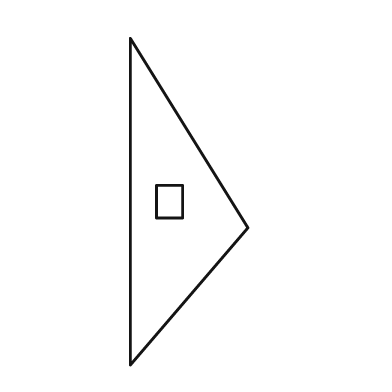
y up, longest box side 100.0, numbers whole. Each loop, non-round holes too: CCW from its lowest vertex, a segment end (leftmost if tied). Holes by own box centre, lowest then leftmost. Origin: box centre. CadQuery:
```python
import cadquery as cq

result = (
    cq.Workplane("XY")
    .moveTo(-18.0, -50.0)
    .lineTo(18.0, -8.0)
    .lineTo(-18.0, 50.0)
    .close()
    .moveTo(-10.0, -5.0)
    .lineTo(-2.0, -5.0)
    .lineTo(-2.0, 5.0)
    .lineTo(-10.0, 5.0)
    .close()
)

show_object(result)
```